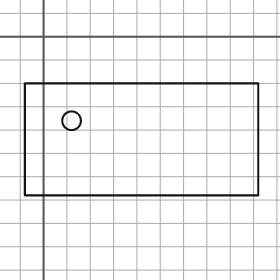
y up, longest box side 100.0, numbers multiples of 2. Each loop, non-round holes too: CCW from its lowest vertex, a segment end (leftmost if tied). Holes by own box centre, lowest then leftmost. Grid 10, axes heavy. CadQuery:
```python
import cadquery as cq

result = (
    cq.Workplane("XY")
    .moveTo(-8.0, -68.0)
    .lineTo(92.0, -68.0)
    .lineTo(92.0, -20.0)
    .lineTo(-8.0, -20.0)
    .close()
    .moveTo(12.0, -36.0)
    .circle(4.0)
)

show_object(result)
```